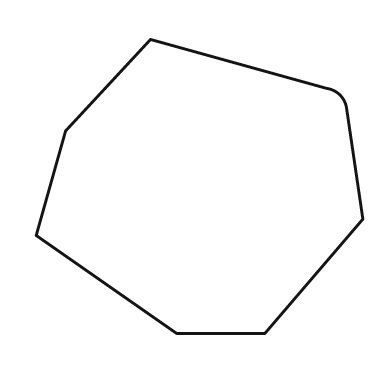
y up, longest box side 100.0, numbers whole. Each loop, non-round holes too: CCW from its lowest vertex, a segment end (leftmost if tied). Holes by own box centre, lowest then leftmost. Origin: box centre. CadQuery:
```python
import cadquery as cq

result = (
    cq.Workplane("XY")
    .moveTo(-7.0, -45.0)
    .lineTo(20.0, -45.0)
    .lineTo(50.0, -10.0)
    .lineTo(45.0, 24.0)
    .threePointArc((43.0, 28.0), (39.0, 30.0))
    .lineTo(-15.0, 45.0)
    .lineTo(-41.0, 17.0)
    .lineTo(-50.0, -15.0)
    .close()
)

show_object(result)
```